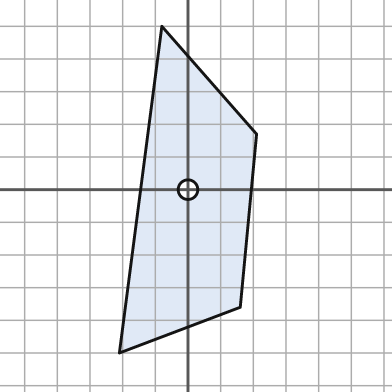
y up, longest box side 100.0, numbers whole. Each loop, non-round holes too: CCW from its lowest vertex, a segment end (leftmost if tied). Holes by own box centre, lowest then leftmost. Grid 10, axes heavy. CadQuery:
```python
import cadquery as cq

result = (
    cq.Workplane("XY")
    .moveTo(-21.0, -50.0)
    .lineTo(16.0, -36.0)
    .lineTo(21.0, 17.0)
    .lineTo(-8.0, 50.0)
    .close()
    .moveTo(0.0, 0.0)
    .circle(3.0)
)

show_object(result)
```